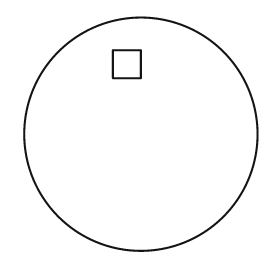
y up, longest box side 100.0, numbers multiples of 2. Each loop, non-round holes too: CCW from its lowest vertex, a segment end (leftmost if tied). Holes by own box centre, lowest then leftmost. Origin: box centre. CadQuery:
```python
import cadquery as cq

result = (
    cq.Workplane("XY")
    .moveTo(0.0, 0.0)
    .circle(50.0)
    .moveTo(-12.0, 24.0)
    .lineTo(0.0, 24.0)
    .lineTo(0.0, 36.0)
    .lineTo(-12.0, 36.0)
    .close()
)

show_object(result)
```